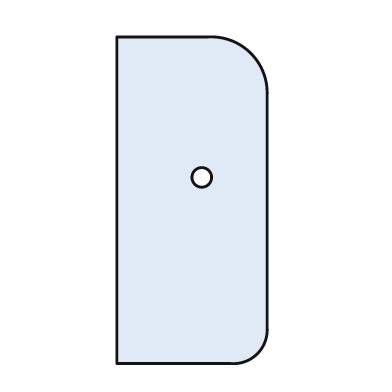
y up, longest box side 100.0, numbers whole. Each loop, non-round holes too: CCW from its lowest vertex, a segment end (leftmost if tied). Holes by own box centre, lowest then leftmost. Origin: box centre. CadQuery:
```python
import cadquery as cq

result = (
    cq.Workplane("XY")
    .moveTo(-23.0, -50.0)
    .lineTo(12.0, -50.0)
    .threePointArc((20.0, -47.0), (23.0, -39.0))
    .lineTo(23.0, 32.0)
    .threePointArc((18.0, 45.0), (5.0, 50.0))
    .lineTo(-23.0, 50.0)
    .close()
    .moveTo(3.0, 7.0)
    .circle(3.0)
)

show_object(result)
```